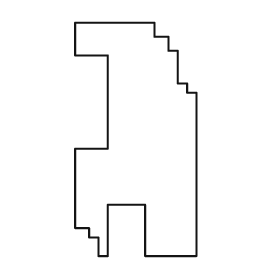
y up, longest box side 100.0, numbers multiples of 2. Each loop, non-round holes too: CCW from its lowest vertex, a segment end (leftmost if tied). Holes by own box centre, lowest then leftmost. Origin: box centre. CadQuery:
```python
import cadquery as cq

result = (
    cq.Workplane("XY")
    .moveTo(-16.0, -50.0)
    .lineTo(-12.0, -50.0)
    .lineTo(-12.0, -28.0)
    .lineTo(4.0, -28.0)
    .lineTo(4.0, -50.0)
    .lineTo(26.0, -50.0)
    .lineTo(26.0, 20.0)
    .lineTo(22.0, 20.0)
    .lineTo(22.0, 24.0)
    .lineTo(18.0, 24.0)
    .lineTo(18.0, 38.0)
    .lineTo(14.0, 38.0)
    .lineTo(14.0, 44.0)
    .lineTo(8.0, 44.0)
    .lineTo(8.0, 50.0)
    .lineTo(-26.0, 50.0)
    .lineTo(-26.0, 36.0)
    .lineTo(-12.0, 36.0)
    .lineTo(-12.0, -4.0)
    .lineTo(-26.0, -4.0)
    .lineTo(-26.0, -38.0)
    .lineTo(-20.0, -38.0)
    .lineTo(-20.0, -42.0)
    .lineTo(-16.0, -42.0)
    .close()
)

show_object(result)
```